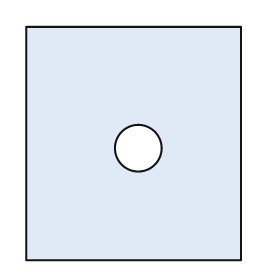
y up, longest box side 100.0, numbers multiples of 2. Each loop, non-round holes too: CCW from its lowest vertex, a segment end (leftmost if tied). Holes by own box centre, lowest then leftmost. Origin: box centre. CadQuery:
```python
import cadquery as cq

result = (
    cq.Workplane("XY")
    .moveTo(-46.0, -50.0)
    .lineTo(46.0, -50.0)
    .lineTo(46.0, 50.0)
    .lineTo(-46.0, 50.0)
    .close()
    .moveTo(2.0, -2.0)
    .circle(10.0)
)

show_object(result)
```